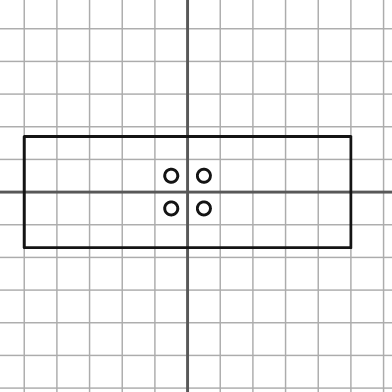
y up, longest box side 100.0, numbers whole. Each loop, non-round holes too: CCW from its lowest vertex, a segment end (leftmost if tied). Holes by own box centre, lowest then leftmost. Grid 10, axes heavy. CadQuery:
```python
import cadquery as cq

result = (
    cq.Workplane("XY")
    .moveTo(-50.0, -17.0)
    .lineTo(50.0, -17.0)
    .lineTo(50.0, 17.0)
    .lineTo(-50.0, 17.0)
    .close()
    .moveTo(-5.0, -5.0)
    .circle(2.0)
    .moveTo(5.0, -5.0)
    .circle(2.0)
    .moveTo(-5.0, 5.0)
    .circle(2.0)
    .moveTo(5.0, 5.0)
    .circle(2.0)
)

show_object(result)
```